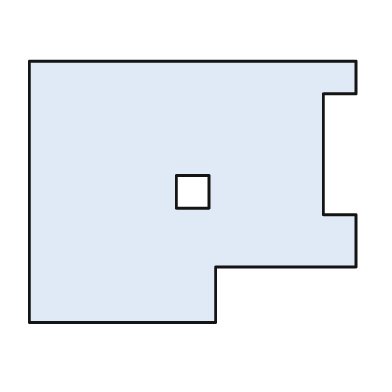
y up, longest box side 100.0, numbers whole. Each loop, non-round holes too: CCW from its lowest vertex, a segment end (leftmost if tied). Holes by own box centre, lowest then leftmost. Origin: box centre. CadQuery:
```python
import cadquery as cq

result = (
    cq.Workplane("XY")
    .moveTo(-50.0, -40.0)
    .lineTo(7.0, -40.0)
    .lineTo(7.0, -23.0)
    .lineTo(50.0, -23.0)
    .lineTo(50.0, -7.0)
    .lineTo(40.0, -7.0)
    .lineTo(40.0, 30.0)
    .lineTo(50.0, 30.0)
    .lineTo(50.0, 40.0)
    .lineTo(-50.0, 40.0)
    .close()
    .moveTo(-5.0, -5.0)
    .lineTo(5.0, -5.0)
    .lineTo(5.0, 5.0)
    .lineTo(-5.0, 5.0)
    .close()
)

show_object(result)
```